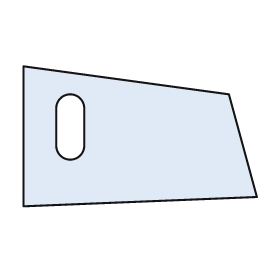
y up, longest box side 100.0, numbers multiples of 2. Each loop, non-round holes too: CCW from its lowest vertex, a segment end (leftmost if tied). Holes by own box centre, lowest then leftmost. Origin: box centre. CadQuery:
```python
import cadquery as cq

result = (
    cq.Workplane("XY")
    .moveTo(-50.0, -30.0)
    .lineTo(50.0, -26.0)
    .lineTo(38.0, 18.0)
    .lineTo(-50.0, 30.0)
    .close()
    .moveTo(-36.0, -4.0)
    .threePointArc((-30.0, -10.0), (-24.0, -4.0))
    .lineTo(-24.0, 12.0)
    .threePointArc((-30.0, 18.0), (-36.0, 12.0))
    .close()
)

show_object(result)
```